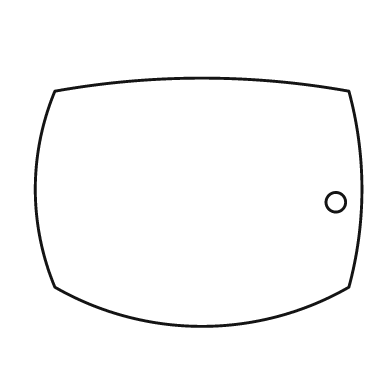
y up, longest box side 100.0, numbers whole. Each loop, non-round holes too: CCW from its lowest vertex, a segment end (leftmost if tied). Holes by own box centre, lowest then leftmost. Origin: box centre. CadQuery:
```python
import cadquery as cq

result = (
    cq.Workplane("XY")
    .moveTo(-44.0, -26.0)
    .threePointArc((1.0, -38.0), (46.0, -26.0))
    .threePointArc((50.0, 4.0), (46.0, 34.0))
    .threePointArc((1.0, 38.0), (-44.0, 34.0))
    .threePointArc((-50.0, 4.0), (-44.0, -26.0))
    .close()
    .moveTo(42.0, 0.0)
    .circle(3.0)
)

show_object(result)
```